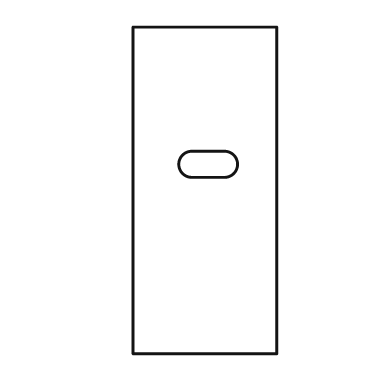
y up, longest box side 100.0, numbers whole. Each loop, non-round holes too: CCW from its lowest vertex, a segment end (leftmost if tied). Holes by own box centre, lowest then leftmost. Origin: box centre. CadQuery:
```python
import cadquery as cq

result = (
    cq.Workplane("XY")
    .moveTo(-22.0, -50.0)
    .lineTo(22.0, -50.0)
    .lineTo(22.0, 50.0)
    .lineTo(-22.0, 50.0)
    .close()
    .moveTo(-4.0, 4.0)
    .lineTo(6.0, 4.0)
    .threePointArc((10.0, 8.0), (6.0, 12.0))
    .lineTo(-4.0, 12.0)
    .threePointArc((-8.0, 8.0), (-4.0, 4.0))
    .close()
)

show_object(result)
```